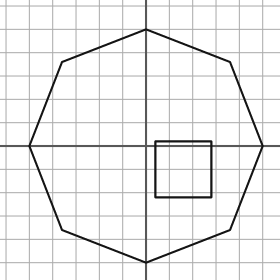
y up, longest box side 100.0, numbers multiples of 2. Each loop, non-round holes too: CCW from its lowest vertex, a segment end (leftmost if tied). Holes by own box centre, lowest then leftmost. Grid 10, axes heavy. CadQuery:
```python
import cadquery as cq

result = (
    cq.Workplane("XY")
    .moveTo(0.0, -50.0)
    .lineTo(36.0, -36.0)
    .lineTo(50.0, 0.0)
    .lineTo(36.0, 36.0)
    .lineTo(0.0, 50.0)
    .lineTo(-36.0, 36.0)
    .lineTo(-50.0, 0.0)
    .lineTo(-36.0, -36.0)
    .close()
    .moveTo(4.0, -22.0)
    .lineTo(28.0, -22.0)
    .lineTo(28.0, 2.0)
    .lineTo(4.0, 2.0)
    .close()
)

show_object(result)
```